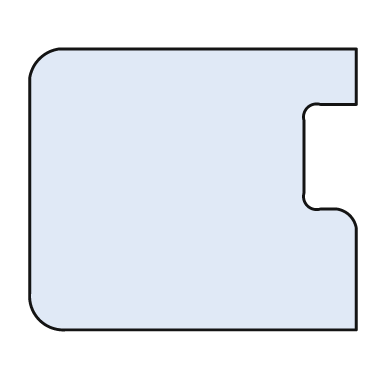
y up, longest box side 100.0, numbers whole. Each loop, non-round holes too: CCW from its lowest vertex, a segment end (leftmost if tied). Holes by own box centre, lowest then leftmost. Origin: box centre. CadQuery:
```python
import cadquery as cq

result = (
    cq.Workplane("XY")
    .moveTo(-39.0, -43.0)
    .lineTo(50.0, -43.0)
    .lineTo(50.0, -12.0)
    .threePointArc((48.0, -8.0), (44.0, -6.0))
    .lineTo(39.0, -6.0)
    .threePointArc((35.0, -5.0), (34.0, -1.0))
    .lineTo(34.0, 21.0)
    .threePointArc((35.0, 25.0), (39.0, 26.0))
    .lineTo(50.0, 26.0)
    .lineTo(50.0, 43.0)
    .lineTo(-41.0, 43.0)
    .threePointArc((-47.0, 40.0), (-50.0, 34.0))
    .lineTo(-50.0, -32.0)
    .threePointArc((-47.0, -40.0), (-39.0, -43.0))
    .close()
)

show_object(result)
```